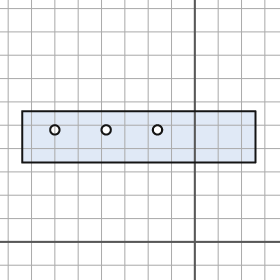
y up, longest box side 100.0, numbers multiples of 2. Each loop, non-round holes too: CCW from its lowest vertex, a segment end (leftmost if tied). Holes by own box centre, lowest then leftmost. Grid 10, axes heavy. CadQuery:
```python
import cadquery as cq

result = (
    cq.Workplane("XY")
    .moveTo(-74.0, 34.0)
    .lineTo(26.0, 34.0)
    .lineTo(26.0, 56.0)
    .lineTo(-74.0, 56.0)
    .close()
    .moveTo(-60.0, 48.0)
    .circle(2.0)
    .moveTo(-38.0, 48.0)
    .circle(2.0)
    .moveTo(-16.0, 48.0)
    .circle(2.0)
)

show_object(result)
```